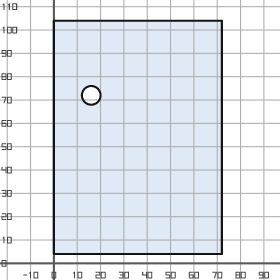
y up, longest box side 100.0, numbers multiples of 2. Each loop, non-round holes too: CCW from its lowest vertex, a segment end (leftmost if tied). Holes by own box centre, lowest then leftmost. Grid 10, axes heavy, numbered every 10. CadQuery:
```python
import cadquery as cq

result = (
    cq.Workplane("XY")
    .moveTo(0.0, 4.0)
    .lineTo(72.0, 4.0)
    .lineTo(72.0, 104.0)
    .lineTo(0.0, 104.0)
    .close()
    .moveTo(16.0, 72.0)
    .circle(4.0)
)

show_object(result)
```